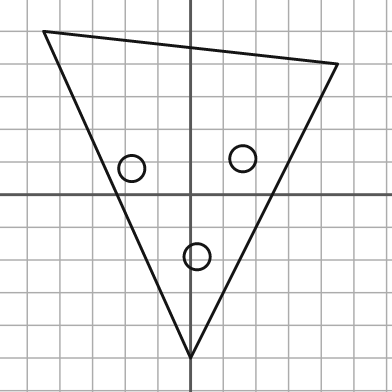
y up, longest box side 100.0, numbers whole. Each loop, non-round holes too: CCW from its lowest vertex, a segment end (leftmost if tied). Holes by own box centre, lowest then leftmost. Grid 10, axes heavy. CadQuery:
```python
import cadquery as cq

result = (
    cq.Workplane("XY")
    .moveTo(0.0, -50.0)
    .lineTo(45.0, 40.0)
    .lineTo(-45.0, 50.0)
    .close()
    .moveTo(2.0, -19.0)
    .circle(4.0)
    .moveTo(-18.0, 8.0)
    .circle(4.0)
    .moveTo(16.0, 11.0)
    .circle(4.0)
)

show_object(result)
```